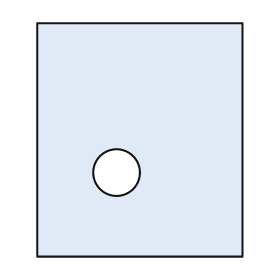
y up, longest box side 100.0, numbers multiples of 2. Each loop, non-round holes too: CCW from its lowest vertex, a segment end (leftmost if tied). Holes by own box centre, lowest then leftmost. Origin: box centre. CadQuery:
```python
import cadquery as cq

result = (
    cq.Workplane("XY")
    .moveTo(-44.0, -50.0)
    .lineTo(44.0, -50.0)
    .lineTo(44.0, 50.0)
    .lineTo(-44.0, 50.0)
    .close()
    .moveTo(-10.0, -14.0)
    .circle(10.0)
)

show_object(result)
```